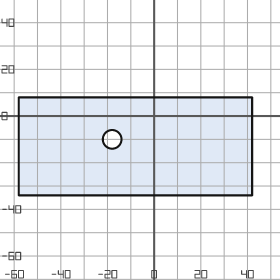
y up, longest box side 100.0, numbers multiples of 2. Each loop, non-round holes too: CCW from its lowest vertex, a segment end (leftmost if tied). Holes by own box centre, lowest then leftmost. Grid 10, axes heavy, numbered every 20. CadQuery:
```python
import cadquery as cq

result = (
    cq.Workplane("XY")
    .moveTo(-58.0, -34.0)
    .lineTo(42.0, -34.0)
    .lineTo(42.0, 8.0)
    .lineTo(-58.0, 8.0)
    .close()
    .moveTo(-18.0, -10.0)
    .circle(4.0)
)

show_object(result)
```